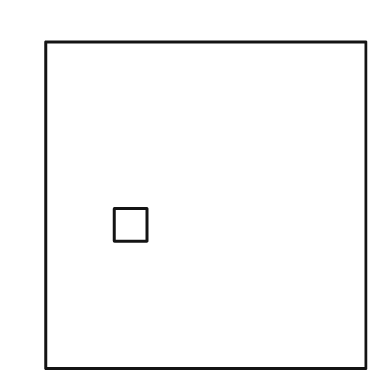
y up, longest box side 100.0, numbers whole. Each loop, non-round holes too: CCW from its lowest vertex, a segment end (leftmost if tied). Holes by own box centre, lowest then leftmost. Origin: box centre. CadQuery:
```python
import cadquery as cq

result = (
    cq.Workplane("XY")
    .moveTo(-49.0, -50.0)
    .lineTo(49.0, -50.0)
    .lineTo(49.0, 50.0)
    .lineTo(-49.0, 50.0)
    .close()
    .moveTo(-28.0, -11.0)
    .lineTo(-18.0, -11.0)
    .lineTo(-18.0, -1.0)
    .lineTo(-28.0, -1.0)
    .close()
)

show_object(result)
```